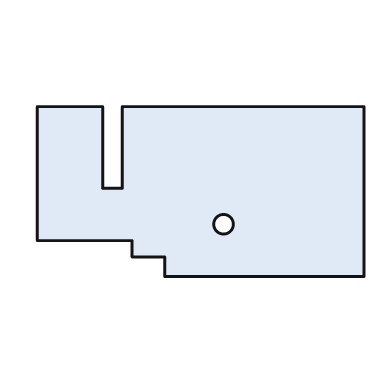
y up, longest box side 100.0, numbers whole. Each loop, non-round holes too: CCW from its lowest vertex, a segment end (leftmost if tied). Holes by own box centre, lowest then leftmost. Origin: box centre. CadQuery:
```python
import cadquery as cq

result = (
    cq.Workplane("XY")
    .moveTo(-11.0, -26.0)
    .lineTo(50.0, -26.0)
    .lineTo(50.0, 26.0)
    .lineTo(-24.0, 26.0)
    .lineTo(-24.0, 1.0)
    .lineTo(-30.0, 1.0)
    .lineTo(-30.0, 26.0)
    .lineTo(-50.0, 26.0)
    .lineTo(-50.0, -15.0)
    .lineTo(-21.0, -15.0)
    .lineTo(-21.0, -20.0)
    .lineTo(-11.0, -20.0)
    .close()
    .moveTo(7.0, -10.0)
    .circle(3.0)
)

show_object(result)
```